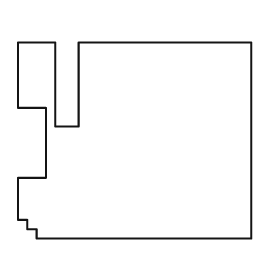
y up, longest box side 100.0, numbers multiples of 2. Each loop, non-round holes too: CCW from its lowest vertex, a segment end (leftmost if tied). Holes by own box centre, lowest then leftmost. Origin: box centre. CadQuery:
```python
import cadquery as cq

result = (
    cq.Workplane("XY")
    .moveTo(-42.0, -42.0)
    .lineTo(50.0, -42.0)
    .lineTo(50.0, 42.0)
    .lineTo(-24.0, 42.0)
    .lineTo(-24.0, 6.0)
    .lineTo(-34.0, 6.0)
    .lineTo(-34.0, 42.0)
    .lineTo(-50.0, 42.0)
    .lineTo(-50.0, 14.0)
    .lineTo(-38.0, 14.0)
    .lineTo(-38.0, -16.0)
    .lineTo(-50.0, -16.0)
    .lineTo(-50.0, -34.0)
    .lineTo(-46.0, -34.0)
    .lineTo(-46.0, -38.0)
    .lineTo(-42.0, -38.0)
    .close()
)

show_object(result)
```